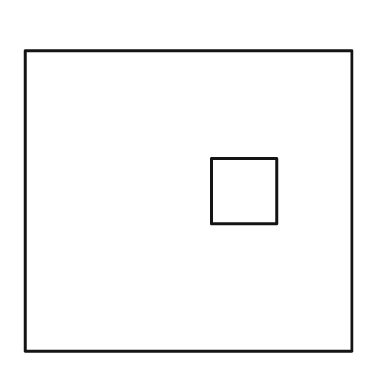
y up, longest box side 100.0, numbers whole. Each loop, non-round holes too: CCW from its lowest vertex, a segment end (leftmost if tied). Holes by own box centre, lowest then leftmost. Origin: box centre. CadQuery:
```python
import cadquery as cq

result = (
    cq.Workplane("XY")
    .moveTo(-50.0, -46.0)
    .lineTo(50.0, -46.0)
    .lineTo(50.0, 46.0)
    .lineTo(-50.0, 46.0)
    .close()
    .moveTo(7.0, -7.0)
    .lineTo(27.0, -7.0)
    .lineTo(27.0, 13.0)
    .lineTo(7.0, 13.0)
    .close()
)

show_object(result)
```